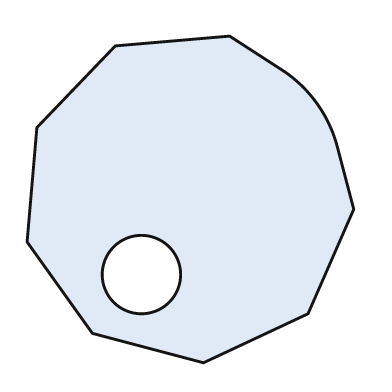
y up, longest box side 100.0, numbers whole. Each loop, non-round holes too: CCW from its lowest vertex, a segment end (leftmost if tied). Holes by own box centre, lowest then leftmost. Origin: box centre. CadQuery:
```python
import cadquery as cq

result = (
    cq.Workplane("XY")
    .moveTo(4.0, -50.0)
    .lineTo(36.0, -35.0)
    .lineTo(50.0, -3.0)
    .lineTo(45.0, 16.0)
    .threePointArc((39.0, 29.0), (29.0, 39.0))
    .lineTo(12.0, 50.0)
    .lineTo(-23.0, 47.0)
    .lineTo(-47.0, 22.0)
    .lineTo(-50.0, -13.0)
    .lineTo(-30.0, -41.0)
    .close()
    .moveTo(-15.0, -23.0)
    .circle(12.0)
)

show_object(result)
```